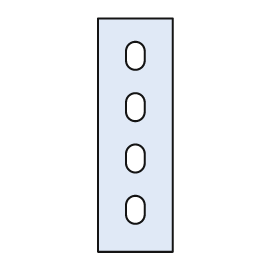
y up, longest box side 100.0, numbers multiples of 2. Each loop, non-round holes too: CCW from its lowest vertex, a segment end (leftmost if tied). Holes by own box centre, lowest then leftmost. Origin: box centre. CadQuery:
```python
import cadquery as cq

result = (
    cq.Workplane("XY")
    .moveTo(-16.0, -50.0)
    .lineTo(16.0, -50.0)
    .lineTo(16.0, 50.0)
    .lineTo(-16.0, 50.0)
    .close()
    .moveTo(-4.0, -34.0)
    .threePointArc((0.0, -38.0), (4.0, -34.0))
    .lineTo(4.0, -30.0)
    .threePointArc((0.0, -26.0), (-4.0, -30.0))
    .close()
    .moveTo(-4.0, -12.0)
    .threePointArc((0.0, -16.0), (4.0, -12.0))
    .lineTo(4.0, -8.0)
    .threePointArc((0.0, -4.0), (-4.0, -8.0))
    .close()
    .moveTo(-4.0, 10.0)
    .threePointArc((0.0, 6.0), (4.0, 10.0))
    .lineTo(4.0, 14.0)
    .threePointArc((0.0, 18.0), (-4.0, 14.0))
    .close()
    .moveTo(-4.0, 32.0)
    .threePointArc((0.0, 28.0), (4.0, 32.0))
    .lineTo(4.0, 36.0)
    .threePointArc((0.0, 40.0), (-4.0, 36.0))
    .close()
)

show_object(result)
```